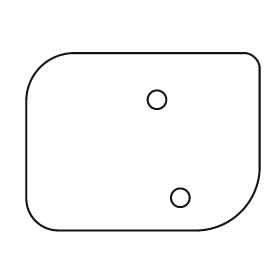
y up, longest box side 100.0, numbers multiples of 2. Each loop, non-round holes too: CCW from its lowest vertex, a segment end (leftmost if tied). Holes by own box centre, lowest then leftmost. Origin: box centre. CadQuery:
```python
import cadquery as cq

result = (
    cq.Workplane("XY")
    .moveTo(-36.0, -38.0)
    .lineTo(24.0, -38.0)
    .threePointArc((42.0, -30.0), (50.0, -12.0))
    .lineTo(50.0, 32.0)
    .threePointArc((48.0, 36.0), (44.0, 38.0))
    .lineTo(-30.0, 38.0)
    .threePointArc((-44.0, 32.0), (-50.0, 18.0))
    .lineTo(-50.0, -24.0)
    .threePointArc((-46.0, -34.0), (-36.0, -38.0))
    .close()
    .moveTo(16.0, -24.0)
    .circle(4.0)
    .moveTo(6.0, 18.0)
    .circle(4.0)
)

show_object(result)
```